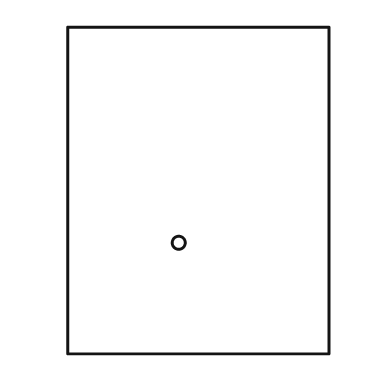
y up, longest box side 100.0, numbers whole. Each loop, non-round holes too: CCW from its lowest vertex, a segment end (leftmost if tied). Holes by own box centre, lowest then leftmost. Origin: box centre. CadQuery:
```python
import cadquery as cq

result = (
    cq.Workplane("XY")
    .moveTo(-40.0, -50.0)
    .lineTo(40.0, -50.0)
    .lineTo(40.0, 50.0)
    .lineTo(-40.0, 50.0)
    .close()
    .moveTo(-6.0, -16.0)
    .circle(2.0)
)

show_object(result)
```